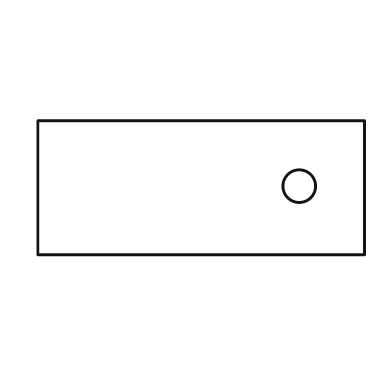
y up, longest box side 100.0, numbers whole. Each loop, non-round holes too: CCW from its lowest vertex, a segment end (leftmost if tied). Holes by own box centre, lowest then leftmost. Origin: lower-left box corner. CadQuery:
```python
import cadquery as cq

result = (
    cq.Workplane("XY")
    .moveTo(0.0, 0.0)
    .lineTo(100.0, 0.0)
    .lineTo(100.0, 41.0)
    .lineTo(0.0, 41.0)
    .close()
    .moveTo(80.0, 21.0)
    .circle(5.0)
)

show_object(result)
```